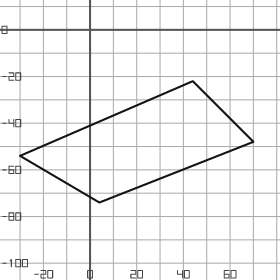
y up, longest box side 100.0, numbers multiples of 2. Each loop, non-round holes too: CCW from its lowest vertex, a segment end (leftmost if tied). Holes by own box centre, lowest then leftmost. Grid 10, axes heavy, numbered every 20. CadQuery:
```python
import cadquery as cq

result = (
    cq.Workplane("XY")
    .moveTo(4.0, -74.0)
    .lineTo(70.0, -48.0)
    .lineTo(44.0, -22.0)
    .lineTo(-30.0, -54.0)
    .close()
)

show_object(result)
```